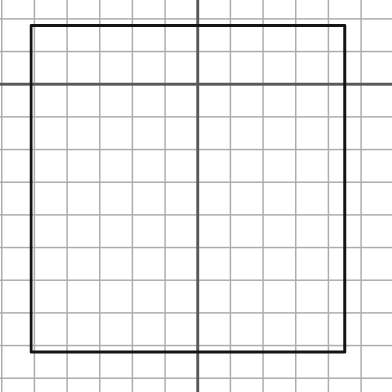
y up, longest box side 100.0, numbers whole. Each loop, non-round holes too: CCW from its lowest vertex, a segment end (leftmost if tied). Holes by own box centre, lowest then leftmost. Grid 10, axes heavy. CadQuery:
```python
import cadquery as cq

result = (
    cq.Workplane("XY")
    .moveTo(-51.0, -82.0)
    .lineTo(45.0, -82.0)
    .lineTo(45.0, 18.0)
    .lineTo(-51.0, 18.0)
    .close()
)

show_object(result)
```